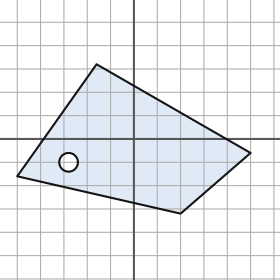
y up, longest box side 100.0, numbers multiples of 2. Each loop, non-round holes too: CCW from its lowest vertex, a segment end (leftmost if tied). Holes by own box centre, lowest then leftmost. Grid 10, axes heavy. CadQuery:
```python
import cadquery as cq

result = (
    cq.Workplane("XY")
    .moveTo(20.0, -32.0)
    .lineTo(50.0, -6.0)
    .lineTo(-16.0, 32.0)
    .lineTo(-50.0, -16.0)
    .close()
    .moveTo(-28.0, -10.0)
    .circle(4.0)
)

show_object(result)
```